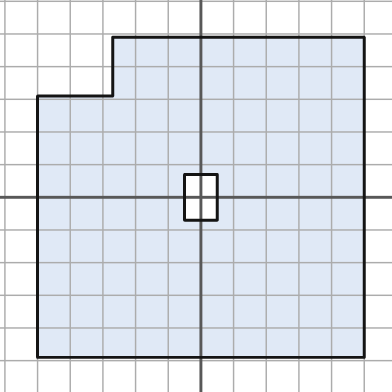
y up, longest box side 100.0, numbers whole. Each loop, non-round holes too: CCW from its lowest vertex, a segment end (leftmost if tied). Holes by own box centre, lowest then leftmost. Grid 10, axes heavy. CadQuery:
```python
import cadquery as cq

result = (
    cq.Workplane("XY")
    .moveTo(-50.0, -49.0)
    .lineTo(50.0, -49.0)
    .lineTo(50.0, 49.0)
    .lineTo(-27.0, 49.0)
    .lineTo(-27.0, 31.0)
    .lineTo(-50.0, 31.0)
    .close()
    .moveTo(-5.0, -7.0)
    .lineTo(5.0, -7.0)
    .lineTo(5.0, 7.0)
    .lineTo(-5.0, 7.0)
    .close()
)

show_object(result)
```